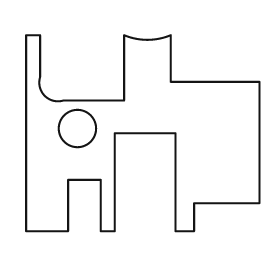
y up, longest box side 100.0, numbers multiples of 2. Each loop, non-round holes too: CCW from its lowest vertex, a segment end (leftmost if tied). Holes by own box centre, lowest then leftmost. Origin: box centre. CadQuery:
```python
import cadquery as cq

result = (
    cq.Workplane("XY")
    .moveTo(-50.0, -42.0)
    .lineTo(-32.0, -42.0)
    .lineTo(-32.0, -20.0)
    .lineTo(-18.0, -20.0)
    .lineTo(-18.0, -42.0)
    .lineTo(-12.0, -42.0)
    .lineTo(-12.0, 0.0)
    .lineTo(14.0, 0.0)
    .lineTo(14.0, -42.0)
    .lineTo(22.0, -42.0)
    .lineTo(22.0, -30.0)
    .lineTo(50.0, -30.0)
    .lineTo(50.0, 22.0)
    .lineTo(12.0, 22.0)
    .lineTo(12.0, 42.0)
    .threePointArc((2.0, 40.0), (-8.0, 42.0))
    .lineTo(-8.0, 14.0)
    .lineTo(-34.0, 14.0)
    .threePointArc((-42.0, 16.0), (-44.0, 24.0))
    .lineTo(-44.0, 42.0)
    .lineTo(-50.0, 42.0)
    .close()
    .moveTo(-28.0, 2.0)
    .circle(8.0)
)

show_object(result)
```